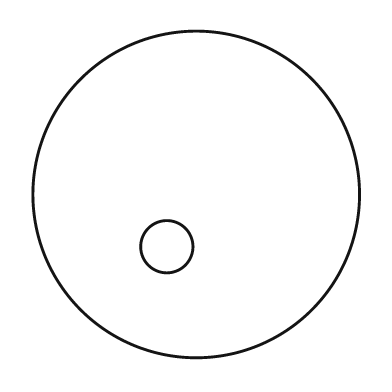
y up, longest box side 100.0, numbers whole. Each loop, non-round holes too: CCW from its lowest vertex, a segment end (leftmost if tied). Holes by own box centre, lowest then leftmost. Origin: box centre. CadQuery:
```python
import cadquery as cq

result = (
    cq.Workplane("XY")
    .moveTo(0.0, 0.0)
    .circle(50.0)
    .moveTo(-9.0, -16.0)
    .circle(8.0)
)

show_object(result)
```